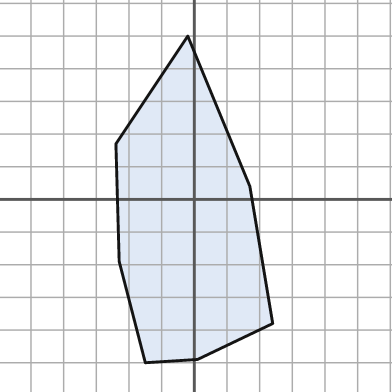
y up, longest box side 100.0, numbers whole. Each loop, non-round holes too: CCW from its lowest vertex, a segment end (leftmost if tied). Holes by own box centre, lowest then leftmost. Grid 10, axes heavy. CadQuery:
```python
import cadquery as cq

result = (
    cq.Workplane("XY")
    .moveTo(-15.0, -50.0)
    .lineTo(1.0, -49.0)
    .lineTo(24.0, -38.0)
    .lineTo(17.0, 4.0)
    .lineTo(-2.0, 50.0)
    .lineTo(-24.0, 17.0)
    .lineTo(-23.0, -19.0)
    .close()
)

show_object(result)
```